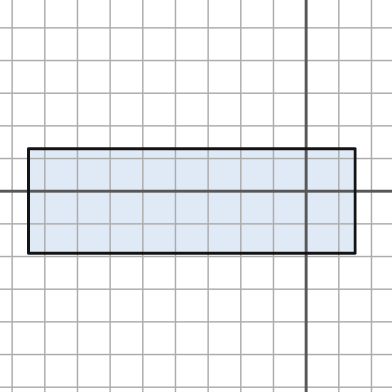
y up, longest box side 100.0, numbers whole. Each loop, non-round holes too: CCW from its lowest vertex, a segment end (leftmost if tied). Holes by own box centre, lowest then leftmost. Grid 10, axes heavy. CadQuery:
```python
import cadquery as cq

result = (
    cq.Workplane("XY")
    .moveTo(-85.0, -19.0)
    .lineTo(15.0, -19.0)
    .lineTo(15.0, 13.0)
    .lineTo(-85.0, 13.0)
    .close()
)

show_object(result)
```